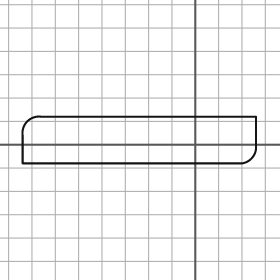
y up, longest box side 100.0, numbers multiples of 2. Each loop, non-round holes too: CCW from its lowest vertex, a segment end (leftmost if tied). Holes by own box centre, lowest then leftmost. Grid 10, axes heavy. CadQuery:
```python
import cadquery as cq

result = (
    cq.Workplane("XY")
    .moveTo(-74.0, -8.0)
    .lineTo(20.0, -8.0)
    .threePointArc((24.0, -6.0), (26.0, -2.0))
    .lineTo(26.0, 12.0)
    .lineTo(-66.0, 12.0)
    .threePointArc((-72.0, 10.0), (-74.0, 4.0))
    .close()
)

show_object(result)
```